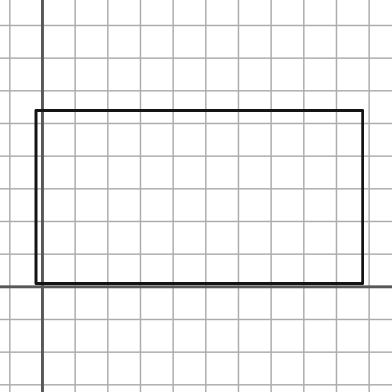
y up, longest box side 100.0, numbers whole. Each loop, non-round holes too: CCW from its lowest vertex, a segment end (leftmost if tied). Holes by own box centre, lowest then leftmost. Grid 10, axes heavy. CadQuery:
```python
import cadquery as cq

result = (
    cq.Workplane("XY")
    .moveTo(-2.0, 1.0)
    .lineTo(98.0, 1.0)
    .lineTo(98.0, 54.0)
    .lineTo(-2.0, 54.0)
    .close()
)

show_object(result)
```